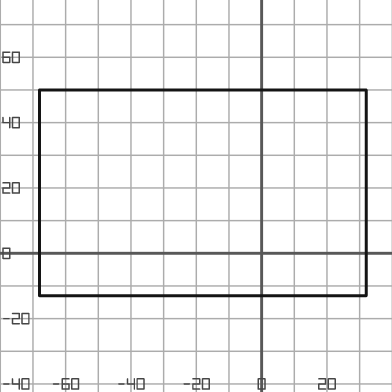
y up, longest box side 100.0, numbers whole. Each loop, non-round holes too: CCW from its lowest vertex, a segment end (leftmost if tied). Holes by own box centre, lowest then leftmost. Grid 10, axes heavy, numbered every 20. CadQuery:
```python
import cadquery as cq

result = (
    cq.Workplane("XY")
    .moveTo(-68.0, -13.0)
    .lineTo(32.0, -13.0)
    .lineTo(32.0, 50.0)
    .lineTo(-68.0, 50.0)
    .close()
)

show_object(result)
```